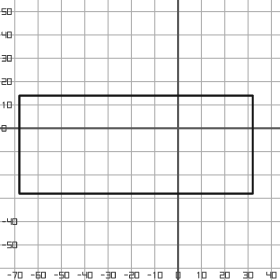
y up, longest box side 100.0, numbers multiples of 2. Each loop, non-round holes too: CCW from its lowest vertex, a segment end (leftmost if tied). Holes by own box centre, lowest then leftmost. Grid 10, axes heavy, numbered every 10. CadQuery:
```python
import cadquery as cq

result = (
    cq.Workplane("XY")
    .moveTo(-68.0, -28.0)
    .lineTo(32.0, -28.0)
    .lineTo(32.0, 14.0)
    .lineTo(-68.0, 14.0)
    .close()
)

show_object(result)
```